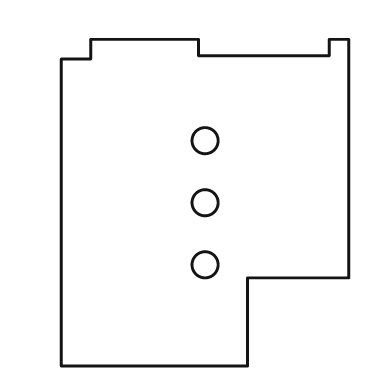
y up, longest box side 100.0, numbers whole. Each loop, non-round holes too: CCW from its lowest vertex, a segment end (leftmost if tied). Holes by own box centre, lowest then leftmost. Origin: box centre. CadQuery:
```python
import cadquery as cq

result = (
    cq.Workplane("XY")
    .moveTo(-44.0, -50.0)
    .lineTo(13.0, -50.0)
    .lineTo(13.0, -23.0)
    .lineTo(44.0, -23.0)
    .lineTo(44.0, 50.0)
    .lineTo(38.0, 50.0)
    .lineTo(38.0, 45.0)
    .lineTo(-2.0, 45.0)
    .lineTo(-2.0, 50.0)
    .lineTo(-35.0, 50.0)
    .lineTo(-35.0, 44.0)
    .lineTo(-44.0, 44.0)
    .close()
    .moveTo(0.0, -19.0)
    .circle(4.0)
    .moveTo(0.0, 0.0)
    .circle(4.0)
    .moveTo(0.0, 19.0)
    .circle(4.0)
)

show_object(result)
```